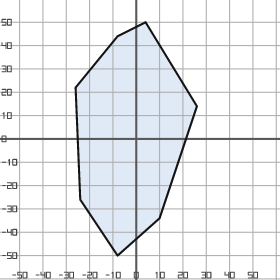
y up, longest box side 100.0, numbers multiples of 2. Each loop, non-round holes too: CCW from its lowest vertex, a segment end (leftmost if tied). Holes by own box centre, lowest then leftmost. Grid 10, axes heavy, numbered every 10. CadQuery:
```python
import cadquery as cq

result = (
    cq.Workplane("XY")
    .moveTo(-8.0, -50.0)
    .lineTo(10.0, -34.0)
    .lineTo(26.0, 14.0)
    .lineTo(4.0, 50.0)
    .lineTo(-8.0, 44.0)
    .lineTo(-26.0, 22.0)
    .lineTo(-24.0, -26.0)
    .close()
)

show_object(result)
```